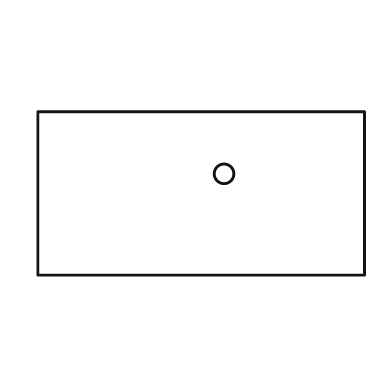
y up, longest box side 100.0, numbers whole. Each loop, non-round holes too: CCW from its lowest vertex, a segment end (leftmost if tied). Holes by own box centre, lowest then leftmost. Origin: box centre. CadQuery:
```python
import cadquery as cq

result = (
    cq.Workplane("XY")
    .moveTo(-50.0, -25.0)
    .lineTo(50.0, -25.0)
    .lineTo(50.0, 25.0)
    .lineTo(-50.0, 25.0)
    .close()
    .moveTo(7.0, 6.0)
    .circle(3.0)
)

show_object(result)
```